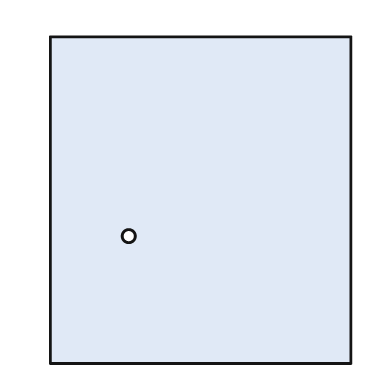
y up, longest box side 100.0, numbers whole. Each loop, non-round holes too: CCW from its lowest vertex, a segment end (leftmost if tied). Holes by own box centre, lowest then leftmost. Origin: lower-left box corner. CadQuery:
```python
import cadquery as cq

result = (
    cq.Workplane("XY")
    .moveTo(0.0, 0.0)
    .lineTo(92.0, 0.0)
    .lineTo(92.0, 100.0)
    .lineTo(0.0, 100.0)
    .close()
    .moveTo(24.0, 39.0)
    .circle(2.0)
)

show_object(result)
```